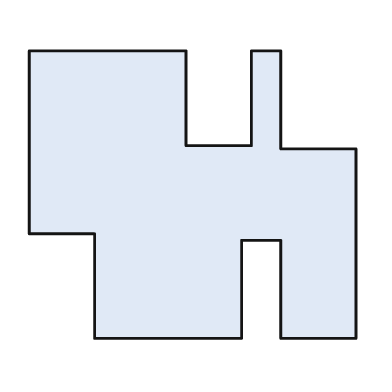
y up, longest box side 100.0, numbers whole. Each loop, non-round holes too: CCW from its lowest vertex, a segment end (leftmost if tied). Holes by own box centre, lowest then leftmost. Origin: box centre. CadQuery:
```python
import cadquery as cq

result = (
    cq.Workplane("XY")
    .moveTo(-30.0, -44.0)
    .lineTo(15.0, -44.0)
    .lineTo(15.0, -14.0)
    .lineTo(27.0, -14.0)
    .lineTo(27.0, -44.0)
    .lineTo(50.0, -44.0)
    .lineTo(50.0, 14.0)
    .lineTo(27.0, 14.0)
    .lineTo(27.0, 44.0)
    .lineTo(18.0, 44.0)
    .lineTo(18.0, 15.0)
    .lineTo(-2.0, 15.0)
    .lineTo(-2.0, 44.0)
    .lineTo(-50.0, 44.0)
    .lineTo(-50.0, -12.0)
    .lineTo(-30.0, -12.0)
    .close()
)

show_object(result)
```